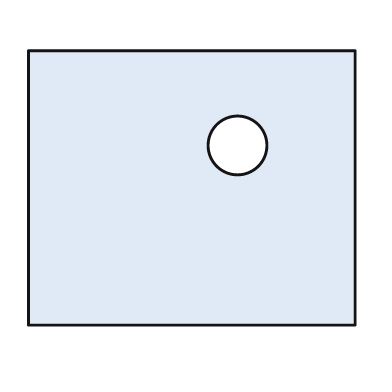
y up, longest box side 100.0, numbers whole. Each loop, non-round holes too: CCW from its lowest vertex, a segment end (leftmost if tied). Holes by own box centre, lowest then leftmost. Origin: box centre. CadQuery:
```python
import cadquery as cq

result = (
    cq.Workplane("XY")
    .moveTo(-50.0, -42.0)
    .lineTo(50.0, -42.0)
    .lineTo(50.0, 42.0)
    .lineTo(-50.0, 42.0)
    .close()
    .moveTo(14.0, 13.0)
    .circle(9.0)
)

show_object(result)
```